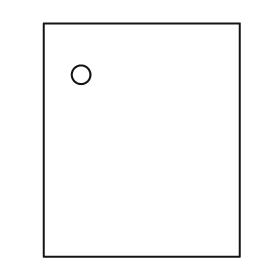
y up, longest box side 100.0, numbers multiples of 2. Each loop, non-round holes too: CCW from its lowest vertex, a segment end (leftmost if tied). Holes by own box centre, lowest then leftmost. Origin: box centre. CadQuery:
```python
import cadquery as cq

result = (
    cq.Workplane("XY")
    .moveTo(-42.0, -50.0)
    .lineTo(42.0, -50.0)
    .lineTo(42.0, 50.0)
    .lineTo(-42.0, 50.0)
    .close()
    .moveTo(-26.0, 28.0)
    .circle(4.0)
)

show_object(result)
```